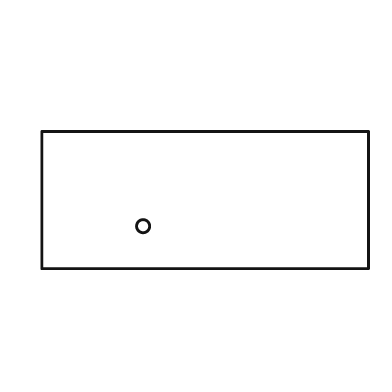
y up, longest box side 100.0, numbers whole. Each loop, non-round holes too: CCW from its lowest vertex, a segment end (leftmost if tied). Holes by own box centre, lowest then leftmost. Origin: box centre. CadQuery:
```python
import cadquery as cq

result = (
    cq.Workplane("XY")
    .moveTo(-50.0, -21.0)
    .lineTo(50.0, -21.0)
    .lineTo(50.0, 21.0)
    .lineTo(-50.0, 21.0)
    .close()
    .moveTo(-19.0, -8.0)
    .circle(2.0)
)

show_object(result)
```